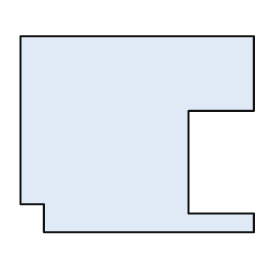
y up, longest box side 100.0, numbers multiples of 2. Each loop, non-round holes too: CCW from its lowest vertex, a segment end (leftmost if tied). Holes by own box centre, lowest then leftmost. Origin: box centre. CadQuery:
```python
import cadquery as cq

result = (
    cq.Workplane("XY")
    .moveTo(-40.0, -42.0)
    .lineTo(50.0, -42.0)
    .lineTo(50.0, -34.0)
    .lineTo(22.0, -34.0)
    .lineTo(22.0, 10.0)
    .lineTo(50.0, 10.0)
    .lineTo(50.0, 42.0)
    .lineTo(-50.0, 42.0)
    .lineTo(-50.0, -30.0)
    .lineTo(-40.0, -30.0)
    .close()
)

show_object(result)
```